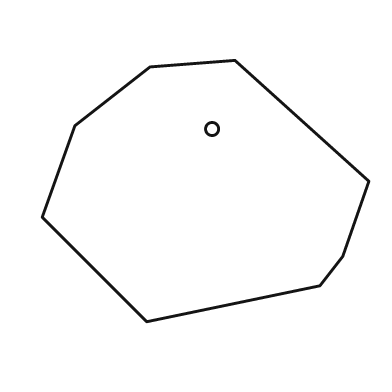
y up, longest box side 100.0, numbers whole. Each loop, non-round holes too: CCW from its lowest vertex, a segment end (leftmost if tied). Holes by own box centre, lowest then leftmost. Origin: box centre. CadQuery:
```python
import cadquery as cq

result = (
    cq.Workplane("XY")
    .moveTo(-18.0, -40.0)
    .lineTo(35.0, -29.0)
    .lineTo(42.0, -20.0)
    .lineTo(50.0, 3.0)
    .lineTo(9.0, 40.0)
    .lineTo(-17.0, 38.0)
    .lineTo(-40.0, 20.0)
    .lineTo(-50.0, -8.0)
    .close()
    .moveTo(2.0, 19.0)
    .circle(2.0)
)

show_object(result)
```